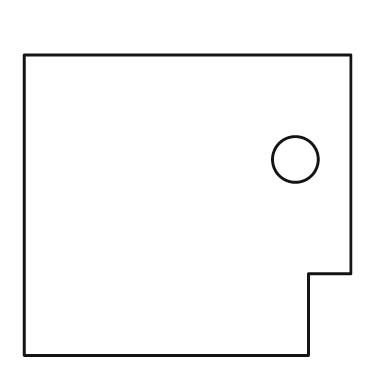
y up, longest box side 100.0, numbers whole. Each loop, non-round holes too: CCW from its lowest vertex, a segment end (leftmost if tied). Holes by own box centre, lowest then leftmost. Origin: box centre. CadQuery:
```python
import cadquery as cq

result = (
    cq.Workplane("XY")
    .moveTo(-50.0, -46.0)
    .lineTo(37.0, -46.0)
    .lineTo(37.0, -21.0)
    .lineTo(50.0, -21.0)
    .lineTo(50.0, 46.0)
    .lineTo(-50.0, 46.0)
    .close()
    .moveTo(33.0, 14.0)
    .circle(7.0)
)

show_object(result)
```